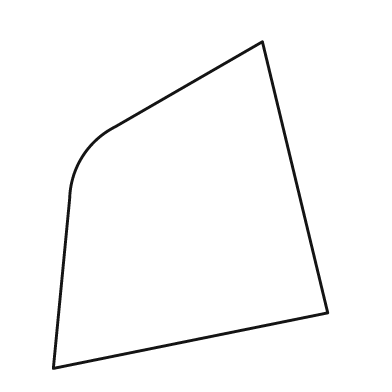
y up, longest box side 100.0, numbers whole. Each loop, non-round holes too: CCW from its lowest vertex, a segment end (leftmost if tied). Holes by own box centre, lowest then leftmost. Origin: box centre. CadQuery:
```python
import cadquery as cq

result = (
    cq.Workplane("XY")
    .moveTo(-42.0, -50.0)
    .lineTo(42.0, -33.0)
    .lineTo(22.0, 50.0)
    .lineTo(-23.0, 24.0)
    .threePointArc((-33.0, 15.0), (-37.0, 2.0))
    .close()
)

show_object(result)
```